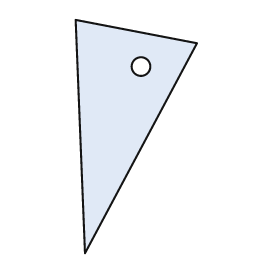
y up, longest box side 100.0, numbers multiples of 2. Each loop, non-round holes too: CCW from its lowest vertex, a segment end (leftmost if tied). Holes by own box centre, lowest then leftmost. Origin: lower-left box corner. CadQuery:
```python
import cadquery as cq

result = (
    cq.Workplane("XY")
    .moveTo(4.0, 0.0)
    .lineTo(52.0, 90.0)
    .lineTo(0.0, 100.0)
    .close()
    .moveTo(28.0, 80.0)
    .circle(4.0)
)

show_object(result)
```